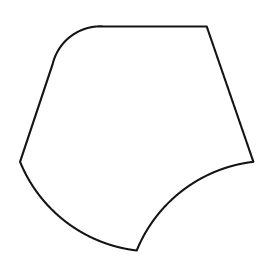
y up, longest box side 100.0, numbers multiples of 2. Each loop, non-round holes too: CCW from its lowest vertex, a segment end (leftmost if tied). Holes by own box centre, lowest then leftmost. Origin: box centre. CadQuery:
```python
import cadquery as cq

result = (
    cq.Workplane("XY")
    .moveTo(0.0, -48.0)
    .threePointArc((20.0, -22.0), (50.0, -10.0))
    .lineTo(30.0, 48.0)
    .lineTo(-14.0, 48.0)
    .threePointArc((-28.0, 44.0), (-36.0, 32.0))
    .lineTo(-50.0, -10.0)
    .threePointArc((-30.0, -36.0), (0.0, -48.0))
    .close()
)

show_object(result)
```